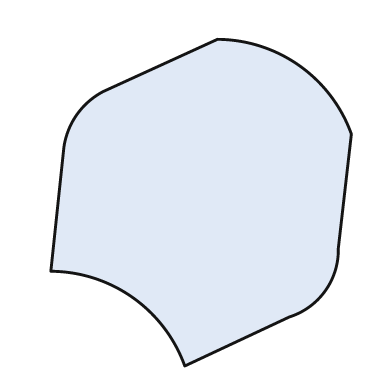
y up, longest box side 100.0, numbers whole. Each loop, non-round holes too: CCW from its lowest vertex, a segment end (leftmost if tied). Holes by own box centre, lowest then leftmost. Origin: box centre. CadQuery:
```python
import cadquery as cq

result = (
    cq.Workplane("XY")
    .moveTo(-5.0, -50.0)
    .lineTo(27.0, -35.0)
    .threePointArc((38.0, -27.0), (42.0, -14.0))
    .lineTo(46.0, 21.0)
    .threePointArc((30.0, 42.0), (5.0, 50.0))
    .lineTo(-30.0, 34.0)
    .threePointArc((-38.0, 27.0), (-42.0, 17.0))
    .lineTo(-46.0, -21.0)
    .threePointArc((-21.0, -29.0), (-5.0, -50.0))
    .close()
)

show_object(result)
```